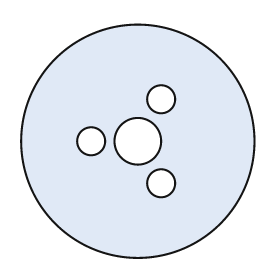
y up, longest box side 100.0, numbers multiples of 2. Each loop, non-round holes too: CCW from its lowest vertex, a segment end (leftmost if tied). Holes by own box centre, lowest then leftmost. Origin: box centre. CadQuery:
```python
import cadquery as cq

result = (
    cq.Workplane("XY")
    .moveTo(0.0, 0.0)
    .circle(50.0)
    .moveTo(10.0, -18.0)
    .circle(6.0)
    .moveTo(-20.0, 0.0)
    .circle(6.0)
    .moveTo(0.0, 0.0)
    .circle(10.0)
    .moveTo(10.0, 18.0)
    .circle(6.0)
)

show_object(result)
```